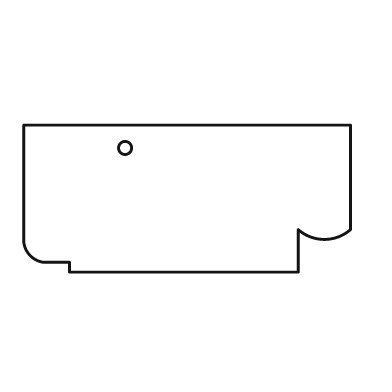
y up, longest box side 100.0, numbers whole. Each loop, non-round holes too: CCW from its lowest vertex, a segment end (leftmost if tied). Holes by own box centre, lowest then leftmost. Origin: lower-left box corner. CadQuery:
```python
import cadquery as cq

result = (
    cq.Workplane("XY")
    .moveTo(14.0, 0.0)
    .lineTo(84.0, 0.0)
    .lineTo(84.0, 13.0)
    .threePointArc((92.0, 10.0), (100.0, 13.0))
    .lineTo(100.0, 45.0)
    .lineTo(0.0, 45.0)
    .lineTo(0.0, 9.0)
    .threePointArc((2.0, 5.0), (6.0, 3.0))
    .lineTo(14.0, 3.0)
    .close()
    .moveTo(31.0, 38.0)
    .circle(2.0)
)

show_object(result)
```